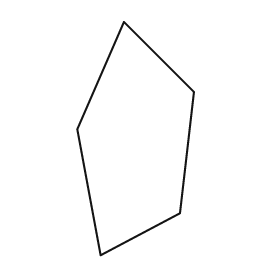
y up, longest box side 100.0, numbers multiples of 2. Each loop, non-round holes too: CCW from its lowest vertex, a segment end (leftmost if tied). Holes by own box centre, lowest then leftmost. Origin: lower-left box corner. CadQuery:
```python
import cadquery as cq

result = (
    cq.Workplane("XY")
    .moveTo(10.0, 0.0)
    .lineTo(44.0, 18.0)
    .lineTo(50.0, 70.0)
    .lineTo(20.0, 100.0)
    .lineTo(0.0, 54.0)
    .close()
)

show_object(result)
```